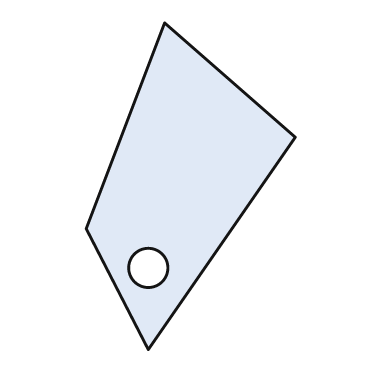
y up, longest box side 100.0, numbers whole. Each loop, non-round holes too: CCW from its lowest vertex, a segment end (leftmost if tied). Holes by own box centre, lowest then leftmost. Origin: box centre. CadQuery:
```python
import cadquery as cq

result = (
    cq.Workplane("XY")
    .moveTo(-13.0, -50.0)
    .lineTo(32.0, 15.0)
    .lineTo(-8.0, 50.0)
    .lineTo(-32.0, -13.0)
    .close()
    .moveTo(-13.0, -25.0)
    .circle(6.0)
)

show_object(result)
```